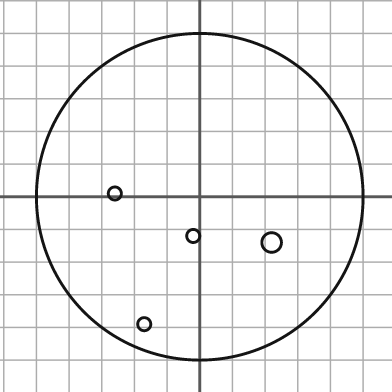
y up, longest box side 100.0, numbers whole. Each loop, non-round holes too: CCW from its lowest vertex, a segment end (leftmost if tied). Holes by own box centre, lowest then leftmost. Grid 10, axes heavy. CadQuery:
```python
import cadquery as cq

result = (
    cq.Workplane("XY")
    .moveTo(0.0, 0.0)
    .circle(50.0)
    .moveTo(-17.0, -39.0)
    .circle(2.0)
    .moveTo(22.0, -14.0)
    .circle(3.0)
    .moveTo(-2.0, -12.0)
    .circle(2.0)
    .moveTo(-26.0, 1.0)
    .circle(2.0)
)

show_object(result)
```